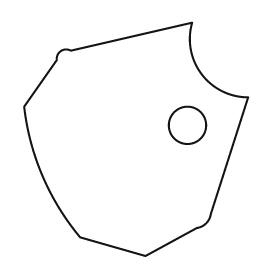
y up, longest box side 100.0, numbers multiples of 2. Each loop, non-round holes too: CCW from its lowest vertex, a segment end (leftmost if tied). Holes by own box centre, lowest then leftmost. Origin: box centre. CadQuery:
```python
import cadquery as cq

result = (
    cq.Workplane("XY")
    .moveTo(4.0, -50.0)
    .lineTo(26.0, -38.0)
    .threePointArc((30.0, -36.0), (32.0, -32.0))
    .lineTo(48.0, 18.0)
    .threePointArc((28.0, 28.0), (24.0, 50.0))
    .lineTo(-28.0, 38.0)
    .threePointArc((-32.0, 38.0), (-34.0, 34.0))
    .lineTo(-48.0, 14.0)
    .threePointArc((-40.0, -16.0), (-24.0, -42.0))
    .close()
    .moveTo(22.0, 6.0)
    .circle(8.0)
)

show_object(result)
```